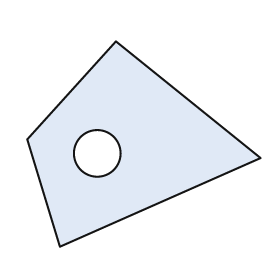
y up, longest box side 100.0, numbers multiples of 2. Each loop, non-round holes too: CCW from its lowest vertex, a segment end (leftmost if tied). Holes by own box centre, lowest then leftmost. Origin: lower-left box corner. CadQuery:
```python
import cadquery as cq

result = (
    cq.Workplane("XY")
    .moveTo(14.0, 0.0)
    .lineTo(100.0, 38.0)
    .lineTo(38.0, 88.0)
    .lineTo(0.0, 46.0)
    .close()
    .moveTo(30.0, 40.0)
    .circle(10.0)
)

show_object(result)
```